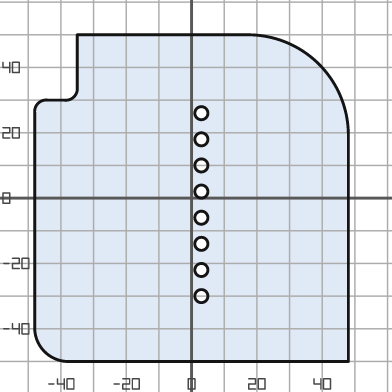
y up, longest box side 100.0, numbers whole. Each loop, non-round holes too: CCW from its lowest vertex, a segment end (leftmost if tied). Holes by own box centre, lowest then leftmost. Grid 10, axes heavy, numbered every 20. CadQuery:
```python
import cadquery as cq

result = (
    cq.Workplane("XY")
    .moveTo(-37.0, -50.0)
    .lineTo(48.0, -50.0)
    .lineTo(48.0, 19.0)
    .threePointArc((39.0, 41.0), (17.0, 50.0))
    .lineTo(-35.0, 50.0)
    .lineTo(-35.0, 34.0)
    .threePointArc((-36.0, 31.0), (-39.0, 30.0))
    .lineTo(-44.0, 30.0)
    .threePointArc((-47.0, 29.0), (-48.0, 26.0))
    .lineTo(-48.0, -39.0)
    .threePointArc((-45.0, -47.0), (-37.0, -50.0))
    .close()
    .moveTo(3.0, -30.0)
    .circle(2.0)
    .moveTo(3.0, -22.0)
    .circle(2.0)
    .moveTo(3.0, -14.0)
    .circle(2.0)
    .moveTo(3.0, -6.0)
    .circle(2.0)
    .moveTo(3.0, 2.0)
    .circle(2.0)
    .moveTo(3.0, 10.0)
    .circle(2.0)
    .moveTo(3.0, 18.0)
    .circle(2.0)
    .moveTo(3.0, 26.0)
    .circle(2.0)
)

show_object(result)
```